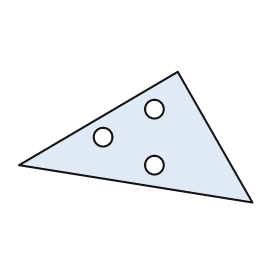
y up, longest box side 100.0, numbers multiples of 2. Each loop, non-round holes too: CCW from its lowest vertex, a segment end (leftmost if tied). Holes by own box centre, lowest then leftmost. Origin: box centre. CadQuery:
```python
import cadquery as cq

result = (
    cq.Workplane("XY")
    .moveTo(50.0, -28.0)
    .lineTo(18.0, 28.0)
    .lineTo(-50.0, -12.0)
    .close()
    .moveTo(8.0, -12.0)
    .circle(4.0)
    .moveTo(-14.0, 0.0)
    .circle(4.0)
    .moveTo(8.0, 12.0)
    .circle(4.0)
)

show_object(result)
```